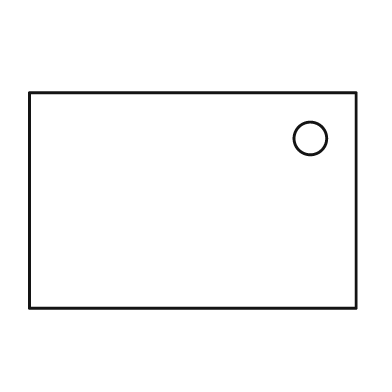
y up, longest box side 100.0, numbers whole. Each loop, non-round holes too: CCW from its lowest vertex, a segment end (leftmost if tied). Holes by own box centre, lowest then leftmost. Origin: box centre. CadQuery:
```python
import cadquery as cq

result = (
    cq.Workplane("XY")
    .moveTo(-50.0, -33.0)
    .lineTo(50.0, -33.0)
    .lineTo(50.0, 33.0)
    .lineTo(-50.0, 33.0)
    .close()
    .moveTo(36.0, 19.0)
    .circle(5.0)
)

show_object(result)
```